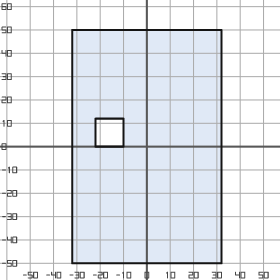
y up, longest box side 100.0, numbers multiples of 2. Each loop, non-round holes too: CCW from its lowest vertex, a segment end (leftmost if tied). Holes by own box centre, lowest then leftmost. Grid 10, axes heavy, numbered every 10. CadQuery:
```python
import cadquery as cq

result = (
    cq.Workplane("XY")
    .moveTo(-32.0, -50.0)
    .lineTo(32.0, -50.0)
    .lineTo(32.0, 50.0)
    .lineTo(-32.0, 50.0)
    .close()
    .moveTo(-22.0, 0.0)
    .lineTo(-10.0, 0.0)
    .lineTo(-10.0, 12.0)
    .lineTo(-22.0, 12.0)
    .close()
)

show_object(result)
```